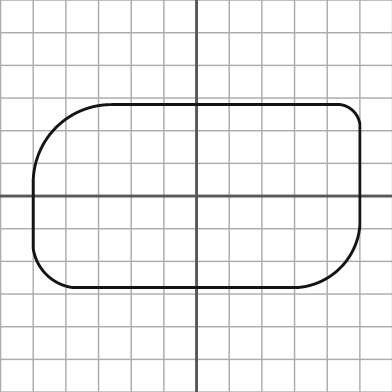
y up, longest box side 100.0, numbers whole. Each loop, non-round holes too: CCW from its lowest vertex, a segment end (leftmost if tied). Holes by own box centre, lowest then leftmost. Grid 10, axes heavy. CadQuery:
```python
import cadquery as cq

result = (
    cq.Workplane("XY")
    .moveTo(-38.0, -28.0)
    .lineTo(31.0, -28.0)
    .threePointArc((44.0, -22.0), (50.0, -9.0))
    .lineTo(50.0, 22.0)
    .threePointArc((48.0, 26.0), (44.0, 28.0))
    .lineTo(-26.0, 28.0)
    .threePointArc((-43.0, 21.0), (-50.0, 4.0))
    .lineTo(-50.0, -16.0)
    .threePointArc((-46.0, -24.0), (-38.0, -28.0))
    .close()
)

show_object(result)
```